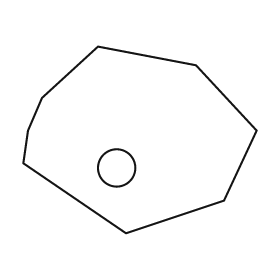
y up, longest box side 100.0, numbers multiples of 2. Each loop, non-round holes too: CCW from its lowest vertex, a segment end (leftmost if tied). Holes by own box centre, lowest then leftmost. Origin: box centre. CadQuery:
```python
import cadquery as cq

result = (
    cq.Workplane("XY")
    .moveTo(-6.0, -40.0)
    .lineTo(36.0, -26.0)
    .lineTo(50.0, 4.0)
    .lineTo(24.0, 32.0)
    .lineTo(-18.0, 40.0)
    .lineTo(-42.0, 18.0)
    .lineTo(-48.0, 4.0)
    .lineTo(-50.0, -10.0)
    .close()
    .moveTo(-10.0, -12.0)
    .circle(8.0)
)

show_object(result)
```